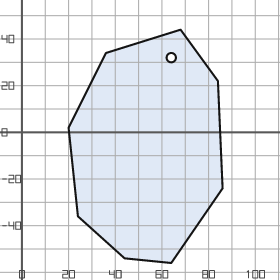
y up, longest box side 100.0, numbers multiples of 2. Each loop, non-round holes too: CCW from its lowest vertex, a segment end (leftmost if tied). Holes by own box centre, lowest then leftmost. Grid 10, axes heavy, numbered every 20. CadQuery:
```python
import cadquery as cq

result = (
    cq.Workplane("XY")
    .moveTo(64.0, -56.0)
    .lineTo(86.0, -24.0)
    .lineTo(84.0, 22.0)
    .lineTo(68.0, 44.0)
    .lineTo(36.0, 34.0)
    .lineTo(20.0, 2.0)
    .lineTo(24.0, -36.0)
    .lineTo(44.0, -54.0)
    .close()
    .moveTo(64.0, 32.0)
    .circle(2.0)
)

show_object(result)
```